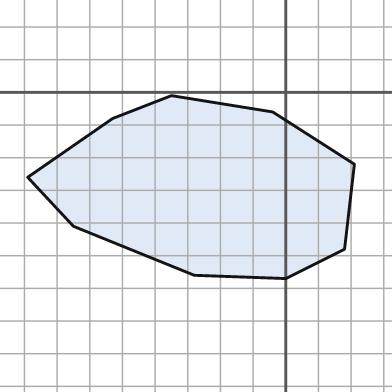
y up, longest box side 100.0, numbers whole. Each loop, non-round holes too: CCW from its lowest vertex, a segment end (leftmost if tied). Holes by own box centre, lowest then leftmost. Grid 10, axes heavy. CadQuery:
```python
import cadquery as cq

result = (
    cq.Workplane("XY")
    .moveTo(0.0, -57.0)
    .lineTo(18.0, -48.0)
    .lineTo(21.0, -22.0)
    .lineTo(-4.0, -6.0)
    .lineTo(-35.0, -1.0)
    .lineTo(-53.0, -8.0)
    .lineTo(-79.0, -26.0)
    .lineTo(-65.0, -41.0)
    .lineTo(-28.0, -56.0)
    .close()
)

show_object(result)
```